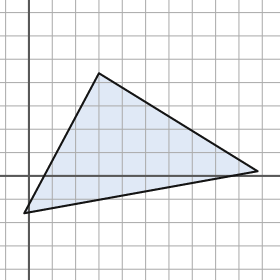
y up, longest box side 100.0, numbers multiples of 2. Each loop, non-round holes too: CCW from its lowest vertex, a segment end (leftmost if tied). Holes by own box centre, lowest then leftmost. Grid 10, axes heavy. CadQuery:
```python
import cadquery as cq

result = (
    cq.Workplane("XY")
    .moveTo(-2.0, -16.0)
    .lineTo(98.0, 2.0)
    .lineTo(30.0, 44.0)
    .close()
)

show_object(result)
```